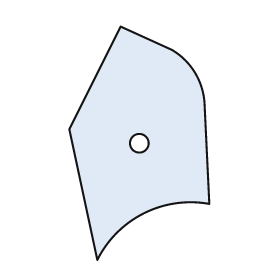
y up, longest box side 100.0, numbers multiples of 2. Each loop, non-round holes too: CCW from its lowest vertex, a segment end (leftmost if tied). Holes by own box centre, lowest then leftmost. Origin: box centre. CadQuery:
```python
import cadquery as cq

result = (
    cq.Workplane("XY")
    .moveTo(-18.0, -50.0)
    .threePointArc((2.0, -30.0), (30.0, -26.0))
    .lineTo(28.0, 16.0)
    .threePointArc((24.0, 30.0), (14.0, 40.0))
    .lineTo(-8.0, 50.0)
    .lineTo(-30.0, 6.0)
    .close()
    .moveTo(0.0, 0.0)
    .circle(4.0)
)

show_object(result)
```